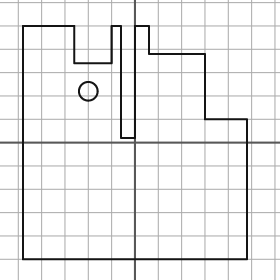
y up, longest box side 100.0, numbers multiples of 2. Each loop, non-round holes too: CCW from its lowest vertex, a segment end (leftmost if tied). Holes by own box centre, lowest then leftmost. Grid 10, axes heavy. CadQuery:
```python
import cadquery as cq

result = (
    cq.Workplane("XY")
    .moveTo(-48.0, -50.0)
    .lineTo(48.0, -50.0)
    .lineTo(48.0, 10.0)
    .lineTo(30.0, 10.0)
    .lineTo(30.0, 38.0)
    .lineTo(6.0, 38.0)
    .lineTo(6.0, 50.0)
    .lineTo(0.0, 50.0)
    .lineTo(0.0, 2.0)
    .lineTo(-6.0, 2.0)
    .lineTo(-6.0, 50.0)
    .lineTo(-10.0, 50.0)
    .lineTo(-10.0, 34.0)
    .lineTo(-26.0, 34.0)
    .lineTo(-26.0, 50.0)
    .lineTo(-48.0, 50.0)
    .close()
    .moveTo(-20.0, 22.0)
    .circle(4.0)
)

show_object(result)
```